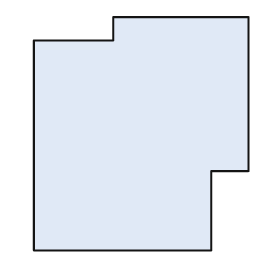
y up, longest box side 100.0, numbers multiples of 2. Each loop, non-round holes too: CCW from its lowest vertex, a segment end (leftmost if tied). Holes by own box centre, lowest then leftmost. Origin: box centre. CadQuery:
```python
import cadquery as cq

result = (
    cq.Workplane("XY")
    .moveTo(-46.0, -50.0)
    .lineTo(30.0, -50.0)
    .lineTo(30.0, -16.0)
    .lineTo(46.0, -16.0)
    .lineTo(46.0, 50.0)
    .lineTo(-12.0, 50.0)
    .lineTo(-12.0, 40.0)
    .lineTo(-46.0, 40.0)
    .close()
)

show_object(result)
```